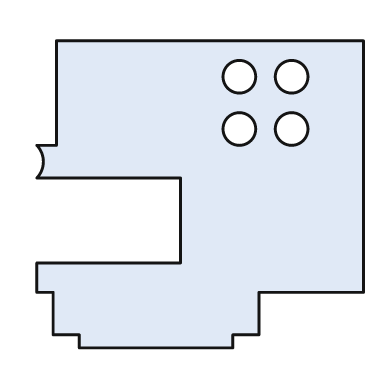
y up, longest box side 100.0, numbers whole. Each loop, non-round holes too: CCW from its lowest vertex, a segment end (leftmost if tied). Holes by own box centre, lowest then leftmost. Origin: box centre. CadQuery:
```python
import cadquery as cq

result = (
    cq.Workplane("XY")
    .moveTo(-37.0, -47.0)
    .lineTo(10.0, -47.0)
    .lineTo(10.0, -43.0)
    .lineTo(18.0, -43.0)
    .lineTo(18.0, -30.0)
    .lineTo(50.0, -30.0)
    .lineTo(50.0, 47.0)
    .lineTo(-44.0, 47.0)
    .lineTo(-44.0, 15.0)
    .lineTo(-50.0, 15.0)
    .threePointArc((-48.0, 10.0), (-50.0, 5.0))
    .lineTo(-6.0, 5.0)
    .lineTo(-6.0, -21.0)
    .lineTo(-50.0, -21.0)
    .lineTo(-50.0, -30.0)
    .lineTo(-45.0, -30.0)
    .lineTo(-45.0, -43.0)
    .lineTo(-37.0, -43.0)
    .close()
    .moveTo(12.0, 20.0)
    .circle(5.0)
    .moveTo(28.0, 20.0)
    .circle(5.0)
    .moveTo(12.0, 36.0)
    .circle(5.0)
    .moveTo(28.0, 36.0)
    .circle(5.0)
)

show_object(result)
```